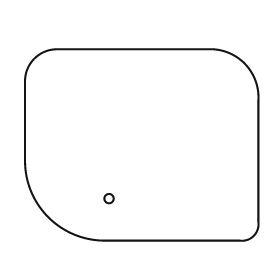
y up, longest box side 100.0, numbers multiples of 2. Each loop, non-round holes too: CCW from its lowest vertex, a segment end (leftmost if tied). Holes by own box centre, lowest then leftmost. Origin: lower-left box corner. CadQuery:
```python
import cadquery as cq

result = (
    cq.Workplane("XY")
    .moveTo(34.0, 0.0)
    .lineTo(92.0, 0.0)
    .threePointArc((98.0, 2.0), (100.0, 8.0))
    .lineTo(100.0, 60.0)
    .threePointArc((94.0, 76.0), (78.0, 82.0))
    .lineTo(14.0, 82.0)
    .threePointArc((4.0, 78.0), (0.0, 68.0))
    .lineTo(0.0, 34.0)
    .threePointArc((10.0, 10.0), (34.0, 0.0))
    .close()
    .moveTo(36.0, 18.0)
    .circle(2.0)
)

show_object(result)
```